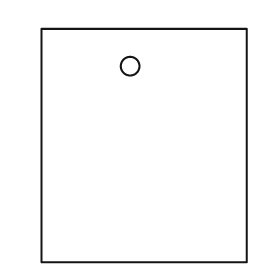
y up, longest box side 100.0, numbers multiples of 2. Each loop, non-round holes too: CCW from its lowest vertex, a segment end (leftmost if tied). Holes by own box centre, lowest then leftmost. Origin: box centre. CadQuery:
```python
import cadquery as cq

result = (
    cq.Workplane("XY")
    .moveTo(-44.0, -50.0)
    .lineTo(44.0, -50.0)
    .lineTo(44.0, 50.0)
    .lineTo(-44.0, 50.0)
    .close()
    .moveTo(-6.0, 34.0)
    .circle(4.0)
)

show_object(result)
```